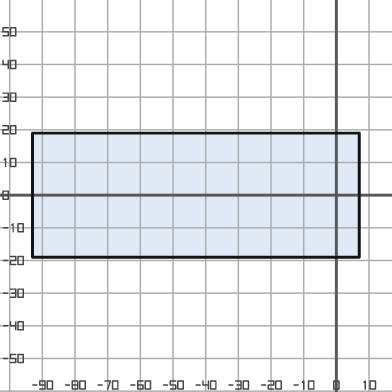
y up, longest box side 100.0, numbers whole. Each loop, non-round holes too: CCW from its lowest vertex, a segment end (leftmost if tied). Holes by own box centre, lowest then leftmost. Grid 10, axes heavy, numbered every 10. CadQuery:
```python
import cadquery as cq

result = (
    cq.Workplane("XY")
    .moveTo(-93.0, -19.0)
    .lineTo(7.0, -19.0)
    .lineTo(7.0, 19.0)
    .lineTo(-93.0, 19.0)
    .close()
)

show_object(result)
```